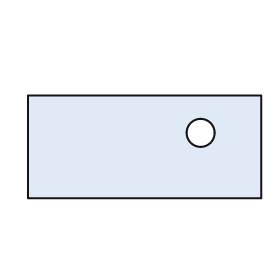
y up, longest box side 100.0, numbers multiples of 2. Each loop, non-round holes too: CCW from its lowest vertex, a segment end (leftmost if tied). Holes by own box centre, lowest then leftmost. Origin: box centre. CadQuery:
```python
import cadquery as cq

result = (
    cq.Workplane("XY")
    .moveTo(-50.0, -22.0)
    .lineTo(50.0, -22.0)
    .lineTo(50.0, 22.0)
    .lineTo(-50.0, 22.0)
    .close()
    .moveTo(24.0, 6.0)
    .circle(6.0)
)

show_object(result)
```